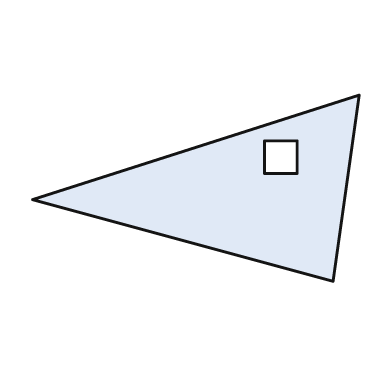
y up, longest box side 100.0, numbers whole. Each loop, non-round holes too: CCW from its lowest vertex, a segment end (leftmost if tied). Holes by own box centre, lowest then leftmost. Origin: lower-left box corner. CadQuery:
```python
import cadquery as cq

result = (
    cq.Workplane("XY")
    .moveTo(92.0, 0.0)
    .lineTo(100.0, 57.0)
    .lineTo(0.0, 25.0)
    .close()
    .moveTo(71.0, 33.0)
    .lineTo(81.0, 33.0)
    .lineTo(81.0, 43.0)
    .lineTo(71.0, 43.0)
    .close()
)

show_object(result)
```